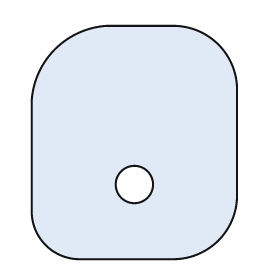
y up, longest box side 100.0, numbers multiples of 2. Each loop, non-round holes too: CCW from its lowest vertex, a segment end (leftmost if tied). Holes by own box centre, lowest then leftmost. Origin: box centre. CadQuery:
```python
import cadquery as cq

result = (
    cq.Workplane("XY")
    .moveTo(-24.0, -50.0)
    .lineTo(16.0, -50.0)
    .threePointArc((36.0, -42.0), (44.0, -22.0))
    .lineTo(44.0, 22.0)
    .threePointArc((36.0, 42.0), (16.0, 50.0))
    .lineTo(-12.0, 50.0)
    .threePointArc((-34.0, 40.0), (-44.0, 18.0))
    .lineTo(-44.0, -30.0)
    .threePointArc((-38.0, -44.0), (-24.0, -50.0))
    .close()
    .moveTo(0.0, -18.0)
    .circle(8.0)
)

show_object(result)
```